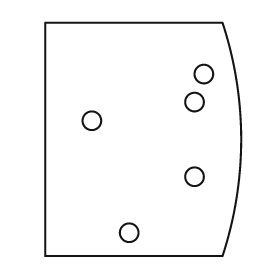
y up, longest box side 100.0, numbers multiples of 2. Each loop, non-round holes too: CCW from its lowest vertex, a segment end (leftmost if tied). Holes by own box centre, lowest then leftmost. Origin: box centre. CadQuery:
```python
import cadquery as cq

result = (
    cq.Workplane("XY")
    .moveTo(-42.0, -50.0)
    .lineTo(34.0, -50.0)
    .threePointArc((42.0, 0.0), (34.0, 50.0))
    .lineTo(-42.0, 50.0)
    .close()
    .moveTo(-6.0, -40.0)
    .circle(4.0)
    .moveTo(22.0, -16.0)
    .circle(4.0)
    .moveTo(-22.0, 8.0)
    .circle(4.0)
    .moveTo(22.0, 16.0)
    .circle(4.0)
    .moveTo(26.0, 28.0)
    .circle(4.0)
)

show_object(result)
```